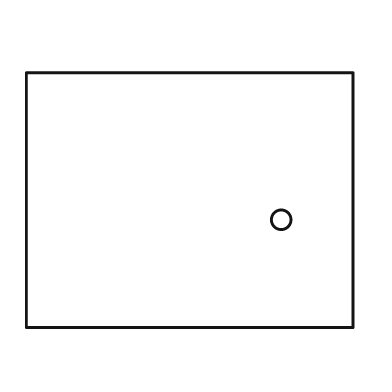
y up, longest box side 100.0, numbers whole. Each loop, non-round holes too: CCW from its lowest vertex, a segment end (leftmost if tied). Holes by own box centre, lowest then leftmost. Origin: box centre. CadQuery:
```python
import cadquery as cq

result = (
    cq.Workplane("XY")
    .moveTo(-50.0, -39.0)
    .lineTo(50.0, -39.0)
    .lineTo(50.0, 39.0)
    .lineTo(-50.0, 39.0)
    .close()
    .moveTo(28.0, -6.0)
    .circle(3.0)
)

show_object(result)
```